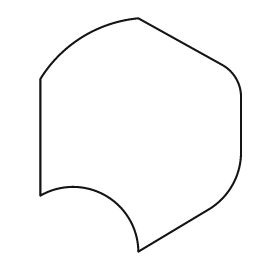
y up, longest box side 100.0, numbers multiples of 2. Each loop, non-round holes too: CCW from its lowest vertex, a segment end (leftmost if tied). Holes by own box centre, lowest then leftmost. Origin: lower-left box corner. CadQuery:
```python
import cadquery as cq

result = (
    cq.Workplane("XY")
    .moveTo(42.0, 0.0)
    .lineTo(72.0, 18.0)
    .threePointArc((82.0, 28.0), (86.0, 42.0))
    .lineTo(86.0, 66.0)
    .threePointArc((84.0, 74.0), (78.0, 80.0))
    .lineTo(42.0, 100.0)
    .threePointArc((18.0, 92.0), (0.0, 74.0))
    .lineTo(0.0, 24.0)
    .threePointArc((28.0, 24.0), (42.0, 0.0))
    .close()
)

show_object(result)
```